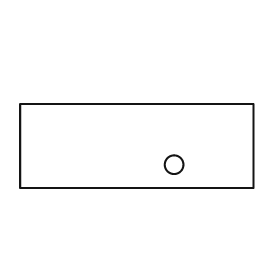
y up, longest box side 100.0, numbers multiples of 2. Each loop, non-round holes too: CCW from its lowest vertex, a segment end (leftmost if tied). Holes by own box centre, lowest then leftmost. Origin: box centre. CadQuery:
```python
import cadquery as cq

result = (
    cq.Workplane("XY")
    .moveTo(-50.0, -18.0)
    .lineTo(50.0, -18.0)
    .lineTo(50.0, 18.0)
    .lineTo(-50.0, 18.0)
    .close()
    .moveTo(16.0, -8.0)
    .circle(4.0)
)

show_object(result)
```